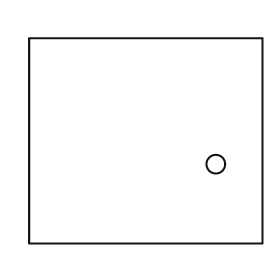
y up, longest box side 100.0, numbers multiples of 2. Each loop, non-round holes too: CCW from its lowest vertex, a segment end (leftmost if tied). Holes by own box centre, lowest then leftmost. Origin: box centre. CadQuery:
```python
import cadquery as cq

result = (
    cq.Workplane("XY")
    .moveTo(-50.0, -44.0)
    .lineTo(50.0, -44.0)
    .lineTo(50.0, 44.0)
    .lineTo(-50.0, 44.0)
    .close()
    .moveTo(30.0, -10.0)
    .circle(4.0)
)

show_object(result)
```